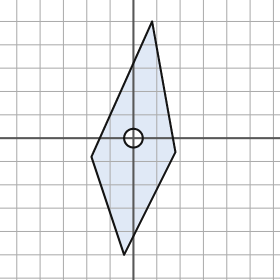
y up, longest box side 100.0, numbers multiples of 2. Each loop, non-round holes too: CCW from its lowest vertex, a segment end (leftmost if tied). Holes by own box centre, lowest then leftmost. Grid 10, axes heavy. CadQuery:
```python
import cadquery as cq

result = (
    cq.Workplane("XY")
    .moveTo(-4.0, -50.0)
    .lineTo(18.0, -6.0)
    .lineTo(8.0, 50.0)
    .lineTo(-18.0, -8.0)
    .close()
    .moveTo(0.0, 0.0)
    .circle(4.0)
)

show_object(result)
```